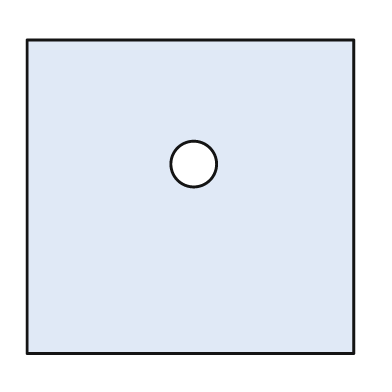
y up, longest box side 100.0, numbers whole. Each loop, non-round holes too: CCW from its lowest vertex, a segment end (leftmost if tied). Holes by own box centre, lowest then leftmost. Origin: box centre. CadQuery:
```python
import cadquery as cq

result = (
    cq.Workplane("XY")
    .moveTo(-50.0, -48.0)
    .lineTo(50.0, -48.0)
    .lineTo(50.0, 48.0)
    .lineTo(-50.0, 48.0)
    .close()
    .moveTo(1.0, 10.0)
    .circle(7.0)
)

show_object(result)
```